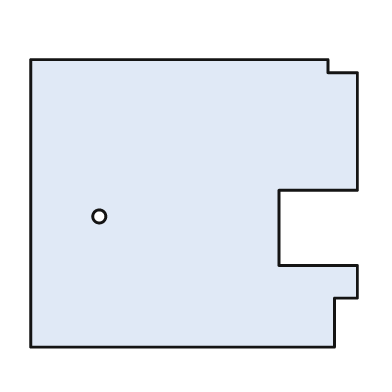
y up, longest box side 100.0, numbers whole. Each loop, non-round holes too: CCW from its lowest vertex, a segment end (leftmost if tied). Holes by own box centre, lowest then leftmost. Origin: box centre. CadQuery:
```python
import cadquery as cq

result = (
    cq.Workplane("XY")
    .moveTo(-50.0, -44.0)
    .lineTo(43.0, -44.0)
    .lineTo(43.0, -29.0)
    .lineTo(50.0, -29.0)
    .lineTo(50.0, -19.0)
    .lineTo(26.0, -19.0)
    .lineTo(26.0, 4.0)
    .lineTo(50.0, 4.0)
    .lineTo(50.0, 40.0)
    .lineTo(41.0, 40.0)
    .lineTo(41.0, 44.0)
    .lineTo(-50.0, 44.0)
    .close()
    .moveTo(-29.0, -4.0)
    .circle(2.0)
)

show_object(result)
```